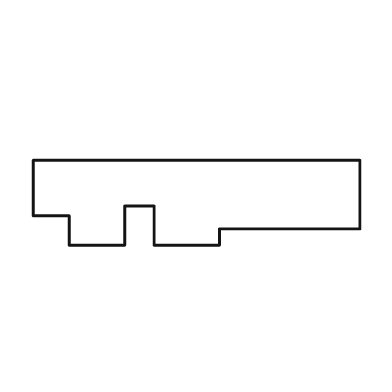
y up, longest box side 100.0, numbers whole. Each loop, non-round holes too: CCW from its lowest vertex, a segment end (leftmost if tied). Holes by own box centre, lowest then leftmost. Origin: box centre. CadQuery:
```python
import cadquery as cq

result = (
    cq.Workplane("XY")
    .moveTo(-39.0, -13.0)
    .lineTo(-22.0, -13.0)
    .lineTo(-22.0, -1.0)
    .lineTo(-13.0, -1.0)
    .lineTo(-13.0, -13.0)
    .lineTo(7.0, -13.0)
    .lineTo(7.0, -8.0)
    .lineTo(50.0, -8.0)
    .lineTo(50.0, 13.0)
    .lineTo(-50.0, 13.0)
    .lineTo(-50.0, -4.0)
    .lineTo(-39.0, -4.0)
    .close()
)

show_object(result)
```